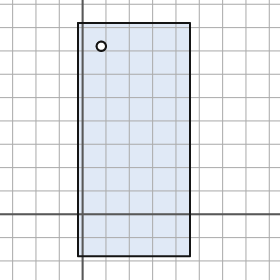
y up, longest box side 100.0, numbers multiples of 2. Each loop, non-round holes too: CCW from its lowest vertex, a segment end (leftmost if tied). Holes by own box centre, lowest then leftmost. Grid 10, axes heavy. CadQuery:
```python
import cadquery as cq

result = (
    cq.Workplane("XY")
    .moveTo(-2.0, -18.0)
    .lineTo(46.0, -18.0)
    .lineTo(46.0, 82.0)
    .lineTo(-2.0, 82.0)
    .close()
    .moveTo(8.0, 72.0)
    .circle(2.0)
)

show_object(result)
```